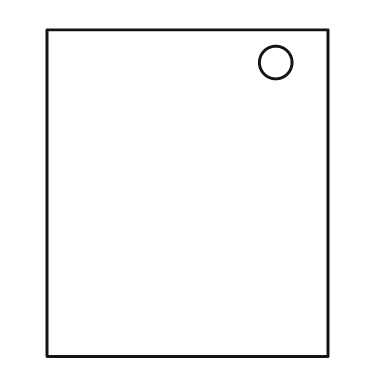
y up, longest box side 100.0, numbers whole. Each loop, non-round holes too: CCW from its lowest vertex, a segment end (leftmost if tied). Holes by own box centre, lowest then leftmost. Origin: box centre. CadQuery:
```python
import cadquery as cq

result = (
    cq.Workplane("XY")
    .moveTo(-43.0, -50.0)
    .lineTo(43.0, -50.0)
    .lineTo(43.0, 50.0)
    .lineTo(-43.0, 50.0)
    .close()
    .moveTo(27.0, 40.0)
    .circle(5.0)
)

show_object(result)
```